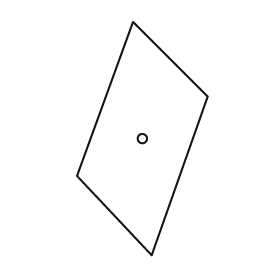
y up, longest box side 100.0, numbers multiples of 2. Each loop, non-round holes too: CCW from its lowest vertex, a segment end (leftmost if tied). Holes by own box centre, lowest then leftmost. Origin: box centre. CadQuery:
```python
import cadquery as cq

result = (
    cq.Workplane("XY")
    .moveTo(4.0, -50.0)
    .lineTo(28.0, 18.0)
    .lineTo(-4.0, 50.0)
    .lineTo(-28.0, -16.0)
    .close()
    .moveTo(0.0, 0.0)
    .circle(2.0)
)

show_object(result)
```